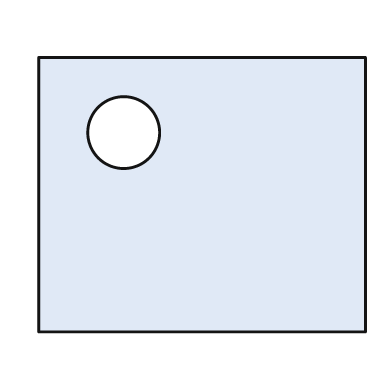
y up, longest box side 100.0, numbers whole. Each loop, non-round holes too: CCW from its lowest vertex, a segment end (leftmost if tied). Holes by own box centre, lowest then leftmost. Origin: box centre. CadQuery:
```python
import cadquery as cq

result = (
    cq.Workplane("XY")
    .moveTo(-50.0, -42.0)
    .lineTo(50.0, -42.0)
    .lineTo(50.0, 42.0)
    .lineTo(-50.0, 42.0)
    .close()
    .moveTo(-24.0, 19.0)
    .circle(11.0)
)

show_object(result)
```